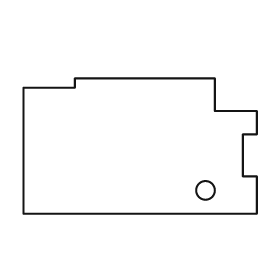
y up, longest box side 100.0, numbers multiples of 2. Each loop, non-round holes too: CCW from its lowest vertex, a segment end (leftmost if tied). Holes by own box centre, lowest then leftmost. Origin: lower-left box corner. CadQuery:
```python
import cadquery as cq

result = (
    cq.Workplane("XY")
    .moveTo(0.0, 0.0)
    .lineTo(100.0, 0.0)
    .lineTo(100.0, 16.0)
    .lineTo(94.0, 16.0)
    .lineTo(94.0, 34.0)
    .lineTo(100.0, 34.0)
    .lineTo(100.0, 44.0)
    .lineTo(82.0, 44.0)
    .lineTo(82.0, 58.0)
    .lineTo(22.0, 58.0)
    .lineTo(22.0, 54.0)
    .lineTo(0.0, 54.0)
    .close()
    .moveTo(78.0, 10.0)
    .circle(4.0)
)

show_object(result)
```